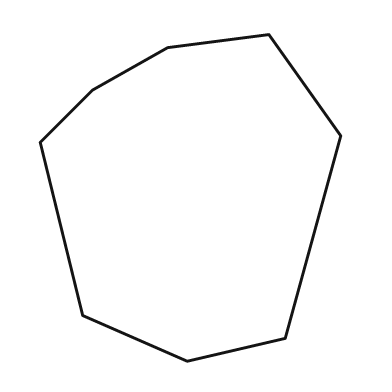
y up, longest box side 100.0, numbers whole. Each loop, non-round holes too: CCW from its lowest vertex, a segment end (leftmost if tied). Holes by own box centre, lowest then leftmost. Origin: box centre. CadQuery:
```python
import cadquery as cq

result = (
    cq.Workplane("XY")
    .moveTo(-1.0, -50.0)
    .lineTo(29.0, -43.0)
    .lineTo(46.0, 19.0)
    .lineTo(24.0, 50.0)
    .lineTo(-7.0, 46.0)
    .lineTo(-30.0, 33.0)
    .lineTo(-46.0, 17.0)
    .lineTo(-33.0, -36.0)
    .close()
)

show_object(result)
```